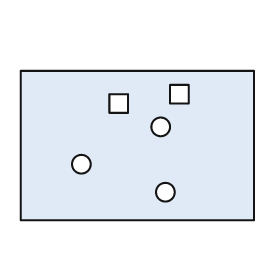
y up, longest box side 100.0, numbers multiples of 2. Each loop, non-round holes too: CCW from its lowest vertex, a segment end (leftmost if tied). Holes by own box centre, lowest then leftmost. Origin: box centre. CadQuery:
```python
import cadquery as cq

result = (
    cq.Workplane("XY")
    .moveTo(-50.0, -32.0)
    .lineTo(50.0, -32.0)
    .lineTo(50.0, 32.0)
    .lineTo(-50.0, 32.0)
    .close()
    .moveTo(12.0, -20.0)
    .circle(4.0)
    .moveTo(-24.0, -8.0)
    .circle(4.0)
    .moveTo(10.0, 8.0)
    .circle(4.0)
    .moveTo(-12.0, 14.0)
    .lineTo(-4.0, 14.0)
    .lineTo(-4.0, 22.0)
    .lineTo(-12.0, 22.0)
    .close()
    .moveTo(14.0, 18.0)
    .lineTo(22.0, 18.0)
    .lineTo(22.0, 26.0)
    .lineTo(14.0, 26.0)
    .close()
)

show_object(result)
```